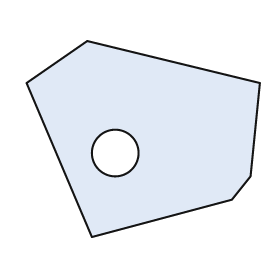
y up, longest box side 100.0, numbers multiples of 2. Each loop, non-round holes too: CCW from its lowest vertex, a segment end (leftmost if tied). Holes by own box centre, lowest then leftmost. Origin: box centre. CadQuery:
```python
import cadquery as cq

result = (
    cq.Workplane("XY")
    .moveTo(-22.0, -42.0)
    .lineTo(38.0, -26.0)
    .lineTo(46.0, -16.0)
    .lineTo(50.0, 24.0)
    .lineTo(-24.0, 42.0)
    .lineTo(-50.0, 24.0)
    .close()
    .moveTo(-12.0, -6.0)
    .circle(10.0)
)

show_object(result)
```